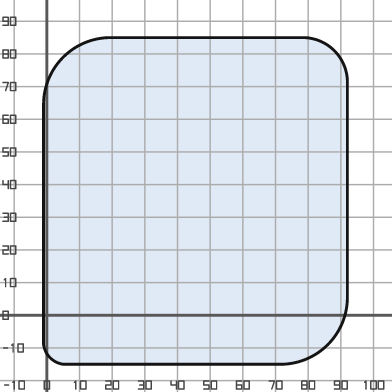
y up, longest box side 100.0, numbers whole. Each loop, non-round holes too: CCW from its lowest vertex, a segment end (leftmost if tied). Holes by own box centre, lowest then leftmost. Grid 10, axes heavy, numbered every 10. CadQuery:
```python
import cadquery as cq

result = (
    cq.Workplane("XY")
    .moveTo(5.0, -15.0)
    .lineTo(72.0, -15.0)
    .threePointArc((86.0, -9.0), (92.0, 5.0))
    .lineTo(92.0, 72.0)
    .threePointArc((88.0, 81.0), (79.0, 85.0))
    .lineTo(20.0, 85.0)
    .threePointArc((5.0, 79.0), (-1.0, 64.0))
    .lineTo(-1.0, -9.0)
    .threePointArc((1.0, -13.0), (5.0, -15.0))
    .close()
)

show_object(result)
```